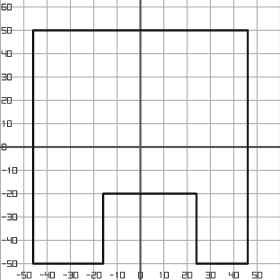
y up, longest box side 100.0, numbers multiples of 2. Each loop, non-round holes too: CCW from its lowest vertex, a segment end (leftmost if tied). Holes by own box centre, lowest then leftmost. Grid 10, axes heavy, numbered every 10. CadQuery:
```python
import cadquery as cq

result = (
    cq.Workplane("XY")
    .moveTo(-46.0, -50.0)
    .lineTo(-16.0, -50.0)
    .lineTo(-16.0, -20.0)
    .lineTo(24.0, -20.0)
    .lineTo(24.0, -50.0)
    .lineTo(46.0, -50.0)
    .lineTo(46.0, 50.0)
    .lineTo(-46.0, 50.0)
    .close()
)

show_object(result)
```